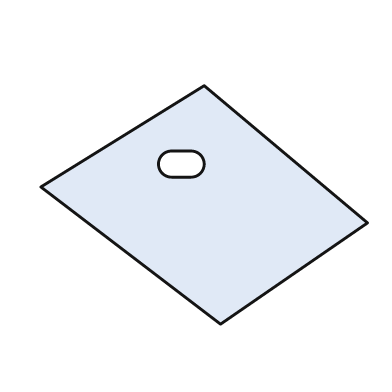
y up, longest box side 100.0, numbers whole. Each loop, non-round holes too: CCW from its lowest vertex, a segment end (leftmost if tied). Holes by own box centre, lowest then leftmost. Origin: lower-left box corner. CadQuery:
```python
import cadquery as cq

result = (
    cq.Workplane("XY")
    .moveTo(55.0, 0.0)
    .lineTo(100.0, 31.0)
    .lineTo(50.0, 73.0)
    .lineTo(0.0, 42.0)
    .close()
    .moveTo(40.0, 45.0)
    .lineTo(46.0, 45.0)
    .threePointArc((50.0, 49.0), (46.0, 53.0))
    .lineTo(40.0, 53.0)
    .threePointArc((36.0, 49.0), (40.0, 45.0))
    .close()
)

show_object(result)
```